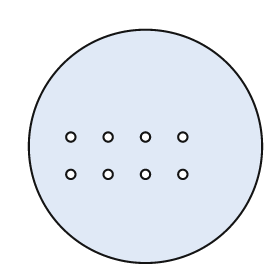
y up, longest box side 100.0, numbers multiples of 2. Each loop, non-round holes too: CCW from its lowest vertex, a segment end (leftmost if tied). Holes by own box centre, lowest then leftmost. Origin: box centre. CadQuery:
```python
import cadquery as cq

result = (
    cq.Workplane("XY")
    .moveTo(0.0, 0.0)
    .circle(50.0)
    .moveTo(-32.0, -12.0)
    .circle(2.0)
    .moveTo(-16.0, -12.0)
    .circle(2.0)
    .moveTo(0.0, -12.0)
    .circle(2.0)
    .moveTo(16.0, -12.0)
    .circle(2.0)
    .moveTo(-32.0, 4.0)
    .circle(2.0)
    .moveTo(-16.0, 4.0)
    .circle(2.0)
    .moveTo(0.0, 4.0)
    .circle(2.0)
    .moveTo(16.0, 4.0)
    .circle(2.0)
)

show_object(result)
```